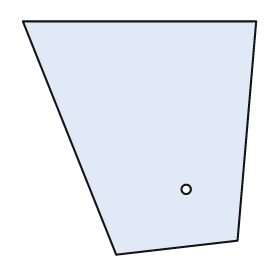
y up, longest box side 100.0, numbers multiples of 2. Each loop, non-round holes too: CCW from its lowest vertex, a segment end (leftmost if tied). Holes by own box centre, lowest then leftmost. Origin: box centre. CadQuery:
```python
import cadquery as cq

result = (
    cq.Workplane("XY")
    .moveTo(-10.0, -50.0)
    .lineTo(42.0, -44.0)
    .lineTo(50.0, 50.0)
    .lineTo(-50.0, 50.0)
    .close()
    .moveTo(20.0, -22.0)
    .circle(2.0)
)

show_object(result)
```